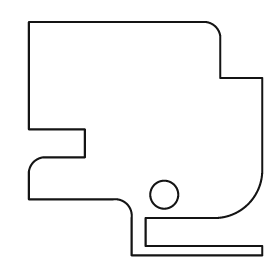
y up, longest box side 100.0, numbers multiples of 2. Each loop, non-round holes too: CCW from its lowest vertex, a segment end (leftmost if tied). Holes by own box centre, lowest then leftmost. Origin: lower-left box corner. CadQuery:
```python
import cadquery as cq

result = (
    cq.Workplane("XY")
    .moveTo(44.0, 0.0)
    .lineTo(100.0, 0.0)
    .lineTo(100.0, 4.0)
    .lineTo(50.0, 4.0)
    .lineTo(50.0, 16.0)
    .lineTo(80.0, 16.0)
    .threePointArc((94.0, 22.0), (100.0, 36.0))
    .lineTo(100.0, 76.0)
    .lineTo(82.0, 76.0)
    .lineTo(82.0, 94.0)
    .threePointArc((80.0, 98.0), (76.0, 100.0))
    .lineTo(0.0, 100.0)
    .lineTo(0.0, 54.0)
    .lineTo(24.0, 54.0)
    .lineTo(24.0, 42.0)
    .lineTo(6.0, 42.0)
    .threePointArc((2.0, 40.0), (0.0, 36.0))
    .lineTo(0.0, 24.0)
    .lineTo(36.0, 24.0)
    .threePointArc((42.0, 22.0), (44.0, 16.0))
    .close()
    .moveTo(58.0, 26.0)
    .circle(6.0)
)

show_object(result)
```